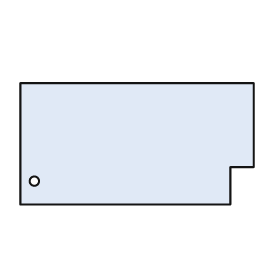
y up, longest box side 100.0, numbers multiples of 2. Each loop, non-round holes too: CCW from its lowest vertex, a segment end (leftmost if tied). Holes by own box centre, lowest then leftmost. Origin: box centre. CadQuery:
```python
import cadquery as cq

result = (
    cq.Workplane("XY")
    .moveTo(-50.0, -26.0)
    .lineTo(40.0, -26.0)
    .lineTo(40.0, -10.0)
    .lineTo(50.0, -10.0)
    .lineTo(50.0, 26.0)
    .lineTo(-50.0, 26.0)
    .close()
    .moveTo(-44.0, -16.0)
    .circle(2.0)
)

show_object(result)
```